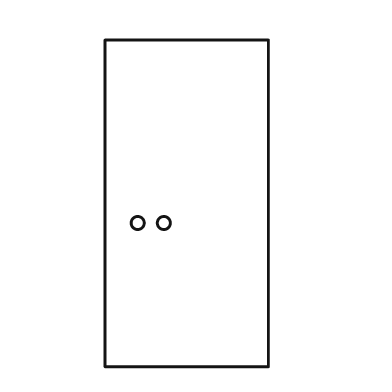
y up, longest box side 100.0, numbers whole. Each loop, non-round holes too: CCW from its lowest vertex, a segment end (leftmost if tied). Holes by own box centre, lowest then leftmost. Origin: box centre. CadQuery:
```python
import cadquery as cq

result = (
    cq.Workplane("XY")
    .moveTo(-25.0, -50.0)
    .lineTo(25.0, -50.0)
    .lineTo(25.0, 50.0)
    .lineTo(-25.0, 50.0)
    .close()
    .moveTo(-15.0, -6.0)
    .circle(2.0)
    .moveTo(-7.0, -6.0)
    .circle(2.0)
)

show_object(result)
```